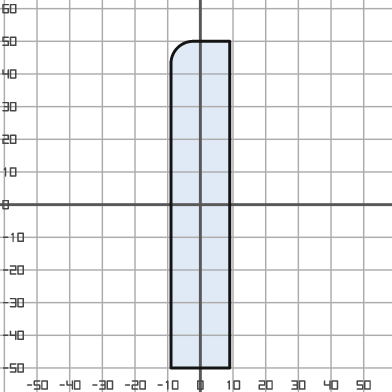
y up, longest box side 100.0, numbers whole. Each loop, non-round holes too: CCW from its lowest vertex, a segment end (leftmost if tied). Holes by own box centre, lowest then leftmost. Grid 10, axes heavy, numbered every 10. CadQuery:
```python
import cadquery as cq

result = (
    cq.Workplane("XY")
    .moveTo(-9.0, -50.0)
    .lineTo(9.0, -50.0)
    .lineTo(9.0, 50.0)
    .lineTo(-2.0, 50.0)
    .threePointArc((-7.0, 48.0), (-9.0, 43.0))
    .close()
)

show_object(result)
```